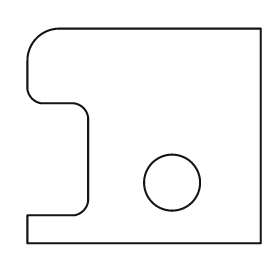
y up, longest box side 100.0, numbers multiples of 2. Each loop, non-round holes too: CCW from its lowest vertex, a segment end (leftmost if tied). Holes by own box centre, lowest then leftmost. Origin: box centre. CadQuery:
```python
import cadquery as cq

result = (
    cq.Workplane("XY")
    .moveTo(-50.0, -46.0)
    .lineTo(50.0, -46.0)
    .lineTo(50.0, 46.0)
    .lineTo(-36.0, 46.0)
    .threePointArc((-46.0, 42.0), (-50.0, 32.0))
    .lineTo(-50.0, 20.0)
    .threePointArc((-48.0, 16.0), (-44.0, 14.0))
    .lineTo(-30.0, 14.0)
    .threePointArc((-26.0, 12.0), (-24.0, 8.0))
    .lineTo(-24.0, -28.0)
    .threePointArc((-26.0, -32.0), (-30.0, -34.0))
    .lineTo(-50.0, -34.0)
    .close()
    .moveTo(12.0, -20.0)
    .circle(12.0)
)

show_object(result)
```